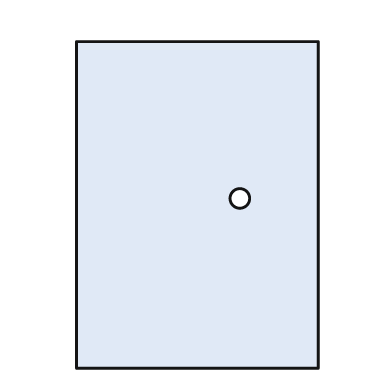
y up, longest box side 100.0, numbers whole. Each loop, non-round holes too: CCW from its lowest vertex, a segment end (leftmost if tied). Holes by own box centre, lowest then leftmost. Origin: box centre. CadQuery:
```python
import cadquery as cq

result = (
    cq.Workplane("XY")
    .moveTo(-37.0, -50.0)
    .lineTo(37.0, -50.0)
    .lineTo(37.0, 50.0)
    .lineTo(-37.0, 50.0)
    .close()
    .moveTo(13.0, 2.0)
    .circle(3.0)
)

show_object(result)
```